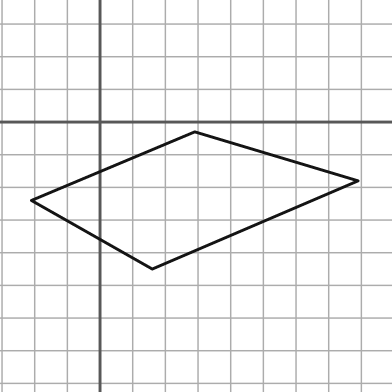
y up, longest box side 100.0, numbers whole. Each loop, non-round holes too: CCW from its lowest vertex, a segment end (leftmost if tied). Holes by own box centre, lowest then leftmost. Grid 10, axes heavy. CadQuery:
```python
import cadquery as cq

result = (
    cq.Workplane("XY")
    .moveTo(16.0, -45.0)
    .lineTo(79.0, -18.0)
    .lineTo(29.0, -3.0)
    .lineTo(-21.0, -24.0)
    .close()
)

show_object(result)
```